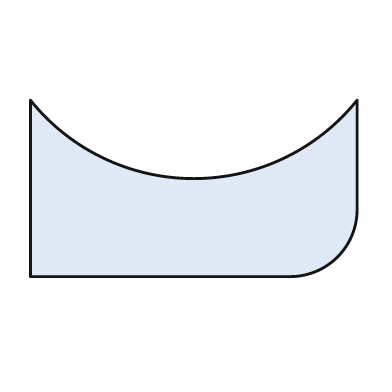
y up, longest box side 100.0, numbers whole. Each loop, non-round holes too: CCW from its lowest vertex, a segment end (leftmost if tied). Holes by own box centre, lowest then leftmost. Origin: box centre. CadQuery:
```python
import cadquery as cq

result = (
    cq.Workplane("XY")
    .moveTo(-50.0, -27.0)
    .lineTo(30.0, -27.0)
    .threePointArc((44.0, -21.0), (50.0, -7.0))
    .lineTo(50.0, 27.0)
    .threePointArc((0.0, 3.0), (-50.0, 27.0))
    .close()
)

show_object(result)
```